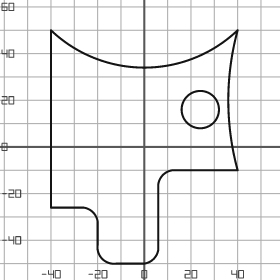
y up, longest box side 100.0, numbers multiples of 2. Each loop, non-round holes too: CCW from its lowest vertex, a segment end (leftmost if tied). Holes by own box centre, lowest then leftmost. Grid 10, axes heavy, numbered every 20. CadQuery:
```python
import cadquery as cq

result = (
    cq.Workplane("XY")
    .moveTo(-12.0, -50.0)
    .lineTo(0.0, -50.0)
    .threePointArc((4.0, -48.0), (6.0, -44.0))
    .lineTo(6.0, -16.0)
    .threePointArc((8.0, -12.0), (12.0, -10.0))
    .lineTo(40.0, -10.0)
    .threePointArc((36.0, 20.0), (40.0, 50.0))
    .threePointArc((0.0, 34.0), (-40.0, 50.0))
    .lineTo(-40.0, -26.0)
    .lineTo(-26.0, -26.0)
    .threePointArc((-22.0, -28.0), (-20.0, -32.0))
    .lineTo(-20.0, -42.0)
    .threePointArc((-18.0, -48.0), (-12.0, -50.0))
    .close()
    .moveTo(24.0, 16.0)
    .circle(8.0)
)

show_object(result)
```